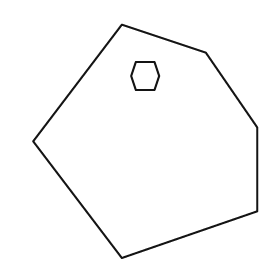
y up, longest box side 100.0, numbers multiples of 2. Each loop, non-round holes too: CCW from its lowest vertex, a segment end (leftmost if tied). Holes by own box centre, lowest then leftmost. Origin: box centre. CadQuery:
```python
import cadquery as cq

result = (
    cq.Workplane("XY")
    .moveTo(-10.0, -50.0)
    .lineTo(48.0, -30.0)
    .lineTo(48.0, 6.0)
    .lineTo(26.0, 38.0)
    .lineTo(-10.0, 50.0)
    .lineTo(-48.0, 0.0)
    .close()
    .moveTo(-4.0, 22.0)
    .lineTo(4.0, 22.0)
    .lineTo(6.0, 28.0)
    .lineTo(4.0, 34.0)
    .lineTo(-4.0, 34.0)
    .lineTo(-6.0, 28.0)
    .close()
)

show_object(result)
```